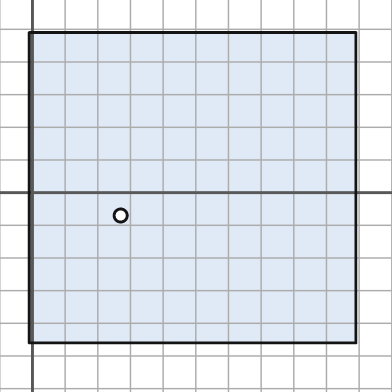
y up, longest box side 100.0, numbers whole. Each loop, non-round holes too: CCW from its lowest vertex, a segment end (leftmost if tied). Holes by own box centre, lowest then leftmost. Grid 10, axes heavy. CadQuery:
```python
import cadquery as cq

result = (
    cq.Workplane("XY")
    .moveTo(-1.0, -46.0)
    .lineTo(99.0, -46.0)
    .lineTo(99.0, 49.0)
    .lineTo(-1.0, 49.0)
    .close()
    .moveTo(27.0, -7.0)
    .circle(2.0)
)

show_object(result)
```